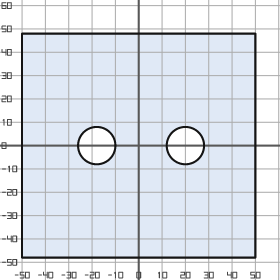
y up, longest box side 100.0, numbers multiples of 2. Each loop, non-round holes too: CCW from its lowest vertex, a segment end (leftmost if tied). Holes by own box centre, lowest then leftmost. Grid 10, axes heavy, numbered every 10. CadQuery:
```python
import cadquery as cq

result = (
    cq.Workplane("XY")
    .moveTo(-50.0, -48.0)
    .lineTo(50.0, -48.0)
    .lineTo(50.0, 48.0)
    .lineTo(-50.0, 48.0)
    .close()
    .moveTo(-18.0, 0.0)
    .circle(8.0)
    .moveTo(20.0, 0.0)
    .circle(8.0)
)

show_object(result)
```